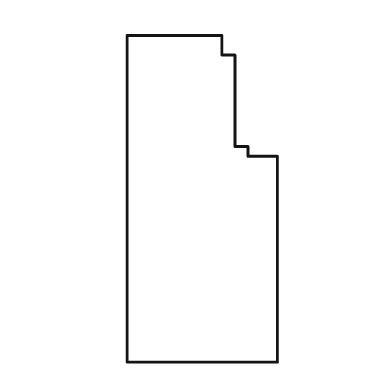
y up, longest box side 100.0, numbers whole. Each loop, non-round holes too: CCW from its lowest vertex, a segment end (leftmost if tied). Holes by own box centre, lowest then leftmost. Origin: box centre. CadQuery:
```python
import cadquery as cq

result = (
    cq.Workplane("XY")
    .moveTo(-23.0, -50.0)
    .lineTo(23.0, -50.0)
    .lineTo(23.0, 13.0)
    .lineTo(14.0, 13.0)
    .lineTo(14.0, 16.0)
    .lineTo(10.0, 16.0)
    .lineTo(10.0, 44.0)
    .lineTo(6.0, 44.0)
    .lineTo(6.0, 50.0)
    .lineTo(-23.0, 50.0)
    .close()
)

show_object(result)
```